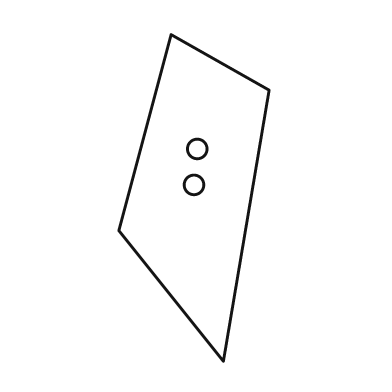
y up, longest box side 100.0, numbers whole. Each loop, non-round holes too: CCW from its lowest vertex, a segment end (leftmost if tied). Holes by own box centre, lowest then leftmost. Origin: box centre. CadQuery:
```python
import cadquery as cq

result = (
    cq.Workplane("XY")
    .moveTo(9.0, -50.0)
    .lineTo(23.0, 33.0)
    .lineTo(-7.0, 50.0)
    .lineTo(-23.0, -10.0)
    .close()
    .moveTo(0.0, 4.0)
    .circle(3.0)
    .moveTo(1.0, 15.0)
    .circle(3.0)
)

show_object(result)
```